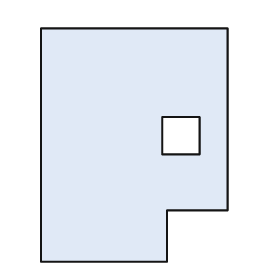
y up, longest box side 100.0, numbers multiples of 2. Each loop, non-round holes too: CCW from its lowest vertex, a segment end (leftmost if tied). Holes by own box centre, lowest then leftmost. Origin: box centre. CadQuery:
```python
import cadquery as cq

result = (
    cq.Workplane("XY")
    .moveTo(-40.0, -50.0)
    .lineTo(14.0, -50.0)
    .lineTo(14.0, -28.0)
    .lineTo(40.0, -28.0)
    .lineTo(40.0, 50.0)
    .lineTo(-40.0, 50.0)
    .close()
    .moveTo(12.0, -4.0)
    .lineTo(28.0, -4.0)
    .lineTo(28.0, 12.0)
    .lineTo(12.0, 12.0)
    .close()
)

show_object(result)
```